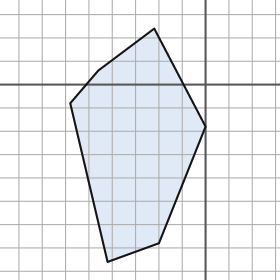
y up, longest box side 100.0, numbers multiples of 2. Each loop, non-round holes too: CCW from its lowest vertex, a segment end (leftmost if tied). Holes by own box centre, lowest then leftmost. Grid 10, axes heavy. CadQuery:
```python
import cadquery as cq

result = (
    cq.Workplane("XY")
    .moveTo(-42.0, -76.0)
    .lineTo(-20.0, -68.0)
    .lineTo(0.0, -18.0)
    .lineTo(-22.0, 24.0)
    .lineTo(-46.0, 6.0)
    .lineTo(-58.0, -8.0)
    .close()
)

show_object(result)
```